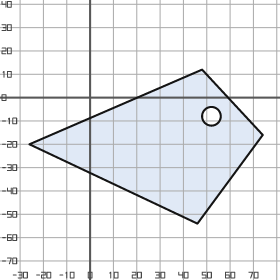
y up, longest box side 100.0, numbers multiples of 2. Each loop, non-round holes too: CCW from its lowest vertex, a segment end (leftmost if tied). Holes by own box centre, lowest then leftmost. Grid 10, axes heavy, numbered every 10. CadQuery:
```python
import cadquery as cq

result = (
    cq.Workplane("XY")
    .moveTo(46.0, -54.0)
    .lineTo(74.0, -16.0)
    .lineTo(48.0, 12.0)
    .lineTo(-26.0, -20.0)
    .close()
    .moveTo(52.0, -8.0)
    .circle(4.0)
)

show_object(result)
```